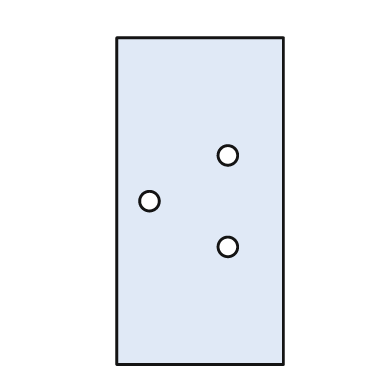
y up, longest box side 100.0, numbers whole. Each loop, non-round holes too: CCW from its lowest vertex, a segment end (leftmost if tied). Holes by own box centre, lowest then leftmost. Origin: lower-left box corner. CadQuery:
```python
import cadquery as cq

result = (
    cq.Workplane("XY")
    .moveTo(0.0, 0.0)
    .lineTo(51.0, 0.0)
    .lineTo(51.0, 100.0)
    .lineTo(0.0, 100.0)
    .close()
    .moveTo(34.0, 36.0)
    .circle(3.0)
    .moveTo(10.0, 50.0)
    .circle(3.0)
    .moveTo(34.0, 64.0)
    .circle(3.0)
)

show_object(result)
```